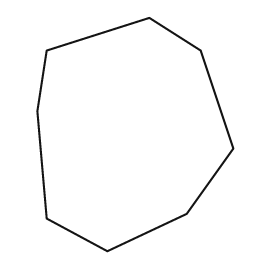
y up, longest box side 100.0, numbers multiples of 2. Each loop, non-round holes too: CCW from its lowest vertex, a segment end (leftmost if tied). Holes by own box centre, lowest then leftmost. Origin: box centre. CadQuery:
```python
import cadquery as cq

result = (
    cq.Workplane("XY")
    .moveTo(-12.0, -50.0)
    .lineTo(22.0, -34.0)
    .lineTo(42.0, -6.0)
    .lineTo(28.0, 36.0)
    .lineTo(6.0, 50.0)
    .lineTo(-38.0, 36.0)
    .lineTo(-42.0, 10.0)
    .lineTo(-38.0, -36.0)
    .close()
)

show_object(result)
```